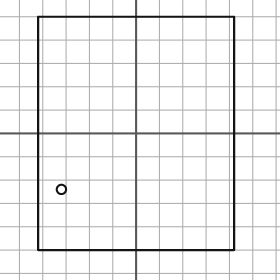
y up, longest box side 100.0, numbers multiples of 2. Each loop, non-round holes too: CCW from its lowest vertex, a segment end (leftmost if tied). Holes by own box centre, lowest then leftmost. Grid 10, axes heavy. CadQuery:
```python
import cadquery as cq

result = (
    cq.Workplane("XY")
    .moveTo(-42.0, -50.0)
    .lineTo(42.0, -50.0)
    .lineTo(42.0, 50.0)
    .lineTo(-42.0, 50.0)
    .close()
    .moveTo(-32.0, -24.0)
    .circle(2.0)
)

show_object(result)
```